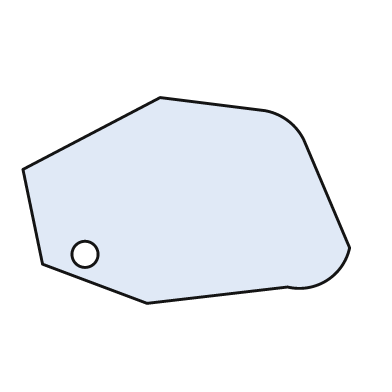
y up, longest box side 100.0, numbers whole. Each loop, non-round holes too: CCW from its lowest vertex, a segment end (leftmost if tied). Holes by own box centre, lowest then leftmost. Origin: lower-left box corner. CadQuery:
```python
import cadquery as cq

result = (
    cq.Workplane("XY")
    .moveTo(38.0, 0.0)
    .lineTo(81.0, 5.0)
    .threePointArc((93.0, 7.0), (100.0, 17.0))
    .lineTo(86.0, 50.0)
    .threePointArc((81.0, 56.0), (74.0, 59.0))
    .lineTo(42.0, 63.0)
    .lineTo(0.0, 41.0)
    .lineTo(6.0, 12.0)
    .close()
    .moveTo(19.0, 15.0)
    .circle(4.0)
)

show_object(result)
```